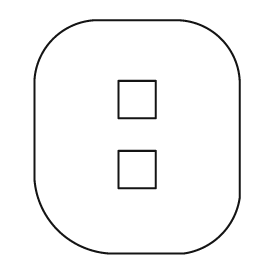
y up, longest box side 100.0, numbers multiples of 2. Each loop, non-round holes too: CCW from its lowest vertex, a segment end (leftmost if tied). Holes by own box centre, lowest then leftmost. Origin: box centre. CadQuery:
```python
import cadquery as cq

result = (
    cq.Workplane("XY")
    .moveTo(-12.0, -50.0)
    .lineTo(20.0, -50.0)
    .threePointArc((36.0, -42.0), (44.0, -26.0))
    .lineTo(44.0, 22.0)
    .threePointArc((36.0, 42.0), (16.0, 50.0))
    .lineTo(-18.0, 50.0)
    .threePointArc((-36.0, 42.0), (-44.0, 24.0))
    .lineTo(-44.0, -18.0)
    .threePointArc((-34.0, -40.0), (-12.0, -50.0))
    .close()
    .moveTo(-8.0, -22.0)
    .lineTo(8.0, -22.0)
    .lineTo(8.0, -6.0)
    .lineTo(-8.0, -6.0)
    .close()
    .moveTo(-8.0, 8.0)
    .lineTo(8.0, 8.0)
    .lineTo(8.0, 24.0)
    .lineTo(-8.0, 24.0)
    .close()
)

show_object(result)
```